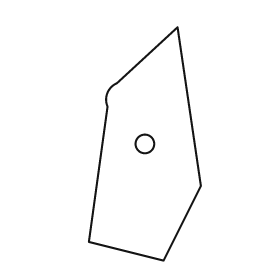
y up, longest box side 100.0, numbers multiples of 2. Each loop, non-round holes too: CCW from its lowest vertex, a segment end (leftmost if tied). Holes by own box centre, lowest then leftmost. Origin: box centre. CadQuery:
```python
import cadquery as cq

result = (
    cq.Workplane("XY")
    .moveTo(8.0, -50.0)
    .lineTo(24.0, -18.0)
    .lineTo(14.0, 50.0)
    .lineTo(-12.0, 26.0)
    .threePointArc((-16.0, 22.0), (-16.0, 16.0))
    .lineTo(-24.0, -42.0)
    .close()
    .moveTo(0.0, 0.0)
    .circle(4.0)
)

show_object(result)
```